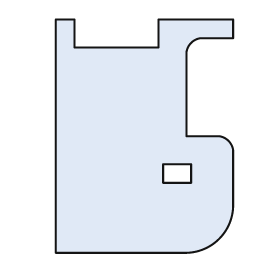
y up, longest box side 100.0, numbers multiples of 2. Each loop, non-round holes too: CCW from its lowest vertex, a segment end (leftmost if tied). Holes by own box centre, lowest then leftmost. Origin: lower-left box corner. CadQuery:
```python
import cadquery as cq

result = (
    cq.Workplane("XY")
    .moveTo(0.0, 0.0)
    .lineTo(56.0, 0.0)
    .threePointArc((70.0, 6.0), (76.0, 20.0))
    .lineTo(76.0, 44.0)
    .threePointArc((74.0, 48.0), (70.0, 50.0))
    .lineTo(56.0, 50.0)
    .lineTo(56.0, 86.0)
    .threePointArc((58.0, 90.0), (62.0, 92.0))
    .lineTo(76.0, 92.0)
    .lineTo(76.0, 100.0)
    .lineTo(44.0, 100.0)
    .lineTo(44.0, 88.0)
    .lineTo(8.0, 88.0)
    .lineTo(8.0, 100.0)
    .lineTo(0.0, 100.0)
    .close()
    .moveTo(46.0, 30.0)
    .lineTo(58.0, 30.0)
    .lineTo(58.0, 38.0)
    .lineTo(46.0, 38.0)
    .close()
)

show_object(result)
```